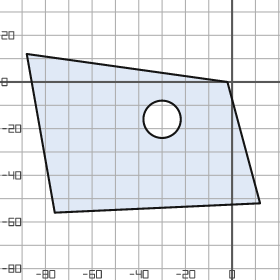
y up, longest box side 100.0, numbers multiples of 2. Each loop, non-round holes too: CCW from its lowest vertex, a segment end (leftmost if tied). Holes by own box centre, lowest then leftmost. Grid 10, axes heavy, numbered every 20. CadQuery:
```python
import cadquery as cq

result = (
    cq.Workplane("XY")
    .moveTo(-76.0, -56.0)
    .lineTo(12.0, -52.0)
    .lineTo(-2.0, 0.0)
    .lineTo(-88.0, 12.0)
    .close()
    .moveTo(-30.0, -16.0)
    .circle(8.0)
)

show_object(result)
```